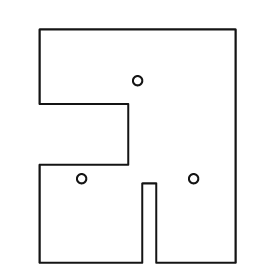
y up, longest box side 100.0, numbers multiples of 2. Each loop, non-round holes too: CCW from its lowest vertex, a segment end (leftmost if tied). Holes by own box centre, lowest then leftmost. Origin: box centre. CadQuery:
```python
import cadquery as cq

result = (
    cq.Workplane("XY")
    .moveTo(-42.0, -50.0)
    .lineTo(2.0, -50.0)
    .lineTo(2.0, -16.0)
    .lineTo(8.0, -16.0)
    .lineTo(8.0, -50.0)
    .lineTo(42.0, -50.0)
    .lineTo(42.0, 50.0)
    .lineTo(-42.0, 50.0)
    .lineTo(-42.0, 18.0)
    .lineTo(-4.0, 18.0)
    .lineTo(-4.0, -8.0)
    .lineTo(-42.0, -8.0)
    .close()
    .moveTo(-24.0, -14.0)
    .circle(2.0)
    .moveTo(24.0, -14.0)
    .circle(2.0)
    .moveTo(0.0, 28.0)
    .circle(2.0)
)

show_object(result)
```